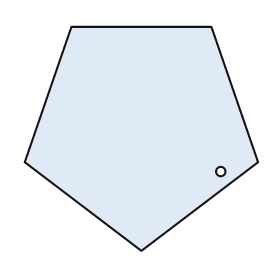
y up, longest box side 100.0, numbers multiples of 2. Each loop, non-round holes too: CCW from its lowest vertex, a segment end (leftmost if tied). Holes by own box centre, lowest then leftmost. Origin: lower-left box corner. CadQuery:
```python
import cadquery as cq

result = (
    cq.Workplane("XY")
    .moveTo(50.0, 0.0)
    .lineTo(100.0, 38.0)
    .lineTo(80.0, 96.0)
    .lineTo(20.0, 96.0)
    .lineTo(0.0, 38.0)
    .close()
    .moveTo(84.0, 34.0)
    .circle(2.0)
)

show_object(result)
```